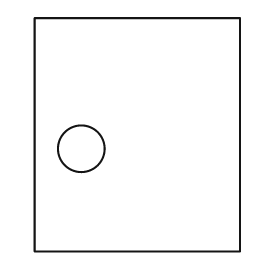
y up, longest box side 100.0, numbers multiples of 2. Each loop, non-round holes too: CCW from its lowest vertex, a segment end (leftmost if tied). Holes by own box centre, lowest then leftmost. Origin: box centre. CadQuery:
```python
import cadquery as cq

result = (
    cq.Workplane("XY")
    .moveTo(-44.0, -50.0)
    .lineTo(44.0, -50.0)
    .lineTo(44.0, 50.0)
    .lineTo(-44.0, 50.0)
    .close()
    .moveTo(-24.0, -6.0)
    .circle(10.0)
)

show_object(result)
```